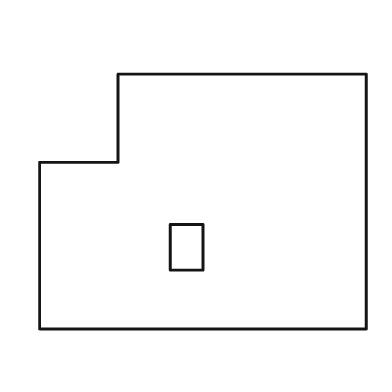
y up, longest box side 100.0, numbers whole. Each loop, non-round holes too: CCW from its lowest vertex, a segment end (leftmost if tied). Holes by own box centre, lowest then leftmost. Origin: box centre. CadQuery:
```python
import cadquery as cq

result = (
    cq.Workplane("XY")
    .moveTo(-50.0, -39.0)
    .lineTo(50.0, -39.0)
    .lineTo(50.0, 39.0)
    .lineTo(-26.0, 39.0)
    .lineTo(-26.0, 12.0)
    .lineTo(-50.0, 12.0)
    .close()
    .moveTo(-10.0, -21.0)
    .lineTo(0.0, -21.0)
    .lineTo(0.0, -7.0)
    .lineTo(-10.0, -7.0)
    .close()
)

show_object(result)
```